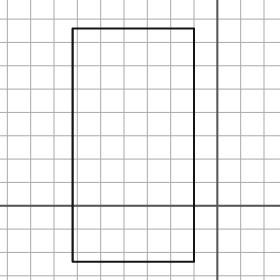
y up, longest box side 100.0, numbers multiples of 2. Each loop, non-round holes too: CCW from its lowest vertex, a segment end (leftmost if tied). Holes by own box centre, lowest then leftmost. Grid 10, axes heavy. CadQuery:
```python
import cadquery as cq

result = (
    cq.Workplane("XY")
    .moveTo(-62.0, -24.0)
    .lineTo(-10.0, -24.0)
    .lineTo(-10.0, 76.0)
    .lineTo(-62.0, 76.0)
    .close()
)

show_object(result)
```